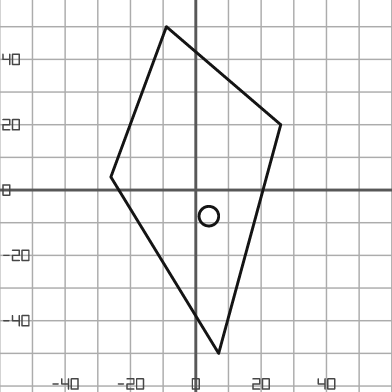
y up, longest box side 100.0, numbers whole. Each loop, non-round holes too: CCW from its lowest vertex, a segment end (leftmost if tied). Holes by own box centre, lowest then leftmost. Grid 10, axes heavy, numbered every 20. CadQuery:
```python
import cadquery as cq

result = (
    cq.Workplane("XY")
    .moveTo(7.0, -50.0)
    .lineTo(26.0, 20.0)
    .lineTo(-9.0, 50.0)
    .lineTo(-26.0, 4.0)
    .close()
    .moveTo(4.0, -8.0)
    .circle(3.0)
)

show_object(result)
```